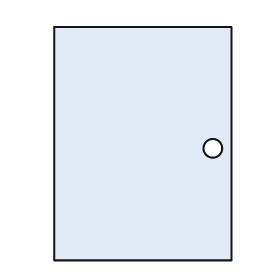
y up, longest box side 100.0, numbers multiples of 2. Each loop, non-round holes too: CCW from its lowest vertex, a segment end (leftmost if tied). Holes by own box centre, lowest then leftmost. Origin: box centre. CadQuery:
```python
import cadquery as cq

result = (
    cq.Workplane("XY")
    .moveTo(-38.0, -50.0)
    .lineTo(38.0, -50.0)
    .lineTo(38.0, 50.0)
    .lineTo(-38.0, 50.0)
    .close()
    .moveTo(30.0, -2.0)
    .circle(4.0)
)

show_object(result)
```